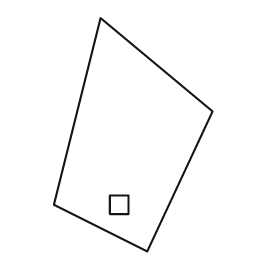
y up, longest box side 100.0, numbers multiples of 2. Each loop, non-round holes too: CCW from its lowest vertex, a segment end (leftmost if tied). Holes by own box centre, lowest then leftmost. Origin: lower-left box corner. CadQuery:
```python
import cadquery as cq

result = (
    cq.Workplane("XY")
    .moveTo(40.0, 0.0)
    .lineTo(68.0, 60.0)
    .lineTo(20.0, 100.0)
    .lineTo(0.0, 20.0)
    .close()
    .moveTo(24.0, 16.0)
    .lineTo(32.0, 16.0)
    .lineTo(32.0, 24.0)
    .lineTo(24.0, 24.0)
    .close()
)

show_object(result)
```